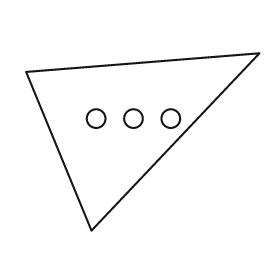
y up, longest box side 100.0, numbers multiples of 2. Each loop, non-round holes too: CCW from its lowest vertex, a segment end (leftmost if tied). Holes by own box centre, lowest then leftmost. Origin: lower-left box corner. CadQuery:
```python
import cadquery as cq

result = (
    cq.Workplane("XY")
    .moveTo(28.0, 0.0)
    .lineTo(100.0, 76.0)
    .lineTo(0.0, 68.0)
    .close()
    .moveTo(30.0, 48.0)
    .circle(4.0)
    .moveTo(46.0, 48.0)
    .circle(4.0)
    .moveTo(62.0, 48.0)
    .circle(4.0)
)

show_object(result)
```